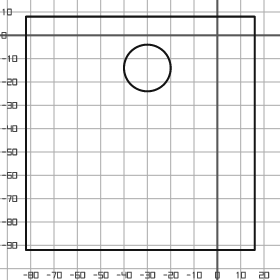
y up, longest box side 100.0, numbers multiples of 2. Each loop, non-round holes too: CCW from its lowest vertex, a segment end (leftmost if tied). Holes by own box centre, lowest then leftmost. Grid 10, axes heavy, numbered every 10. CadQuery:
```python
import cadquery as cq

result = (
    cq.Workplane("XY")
    .moveTo(-82.0, -92.0)
    .lineTo(16.0, -92.0)
    .lineTo(16.0, 8.0)
    .lineTo(-82.0, 8.0)
    .close()
    .moveTo(-30.0, -14.0)
    .circle(10.0)
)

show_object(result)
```